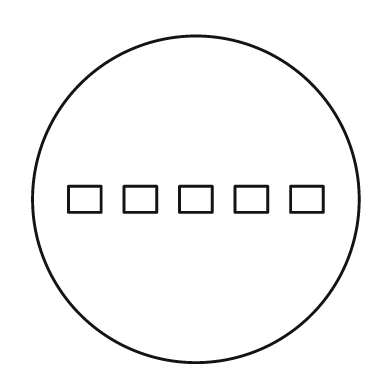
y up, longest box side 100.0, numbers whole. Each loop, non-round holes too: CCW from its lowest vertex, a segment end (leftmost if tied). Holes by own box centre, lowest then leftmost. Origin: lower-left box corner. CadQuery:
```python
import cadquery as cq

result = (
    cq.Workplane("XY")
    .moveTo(50.0, 50.0)
    .circle(50.0)
    .moveTo(11.0, 46.0)
    .lineTo(21.0, 46.0)
    .lineTo(21.0, 54.0)
    .lineTo(11.0, 54.0)
    .close()
    .moveTo(28.0, 46.0)
    .lineTo(38.0, 46.0)
    .lineTo(38.0, 54.0)
    .lineTo(28.0, 54.0)
    .close()
    .moveTo(45.0, 46.0)
    .lineTo(55.0, 46.0)
    .lineTo(55.0, 54.0)
    .lineTo(45.0, 54.0)
    .close()
    .moveTo(62.0, 46.0)
    .lineTo(72.0, 46.0)
    .lineTo(72.0, 54.0)
    .lineTo(62.0, 54.0)
    .close()
    .moveTo(79.0, 46.0)
    .lineTo(89.0, 46.0)
    .lineTo(89.0, 54.0)
    .lineTo(79.0, 54.0)
    .close()
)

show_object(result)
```